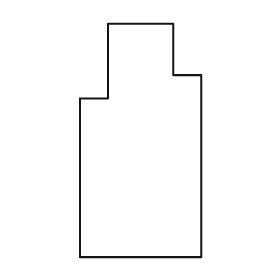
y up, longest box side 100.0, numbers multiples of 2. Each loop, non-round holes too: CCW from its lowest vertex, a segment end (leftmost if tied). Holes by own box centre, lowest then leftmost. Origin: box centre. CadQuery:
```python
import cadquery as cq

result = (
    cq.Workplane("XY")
    .moveTo(-26.0, -50.0)
    .lineTo(26.0, -50.0)
    .lineTo(26.0, 28.0)
    .lineTo(14.0, 28.0)
    .lineTo(14.0, 50.0)
    .lineTo(-14.0, 50.0)
    .lineTo(-14.0, 18.0)
    .lineTo(-26.0, 18.0)
    .close()
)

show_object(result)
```